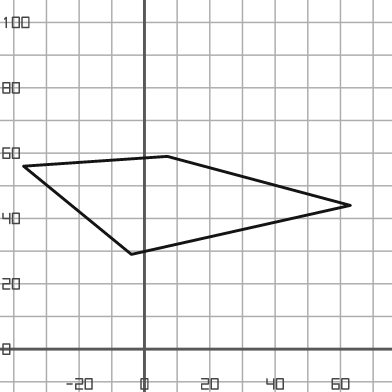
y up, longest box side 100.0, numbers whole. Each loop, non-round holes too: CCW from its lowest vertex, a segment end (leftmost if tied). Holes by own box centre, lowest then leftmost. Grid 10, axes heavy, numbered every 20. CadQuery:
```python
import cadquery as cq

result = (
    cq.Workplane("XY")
    .moveTo(-4.0, 29.0)
    .lineTo(63.0, 44.0)
    .lineTo(7.0, 59.0)
    .lineTo(-37.0, 56.0)
    .close()
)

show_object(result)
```